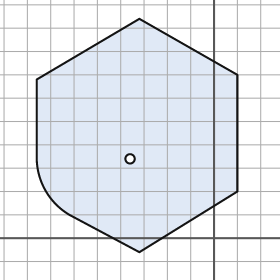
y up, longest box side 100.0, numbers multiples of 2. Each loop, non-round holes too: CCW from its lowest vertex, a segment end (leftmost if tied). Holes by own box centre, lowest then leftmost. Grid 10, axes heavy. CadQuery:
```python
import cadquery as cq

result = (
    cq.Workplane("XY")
    .moveTo(-32.0, -6.0)
    .lineTo(10.0, 20.0)
    .lineTo(10.0, 70.0)
    .lineTo(-32.0, 94.0)
    .lineTo(-76.0, 68.0)
    .lineTo(-76.0, 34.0)
    .threePointArc((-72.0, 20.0), (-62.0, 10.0))
    .close()
    .moveTo(-36.0, 34.0)
    .circle(2.0)
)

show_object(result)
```